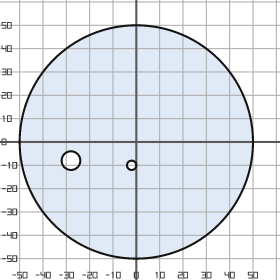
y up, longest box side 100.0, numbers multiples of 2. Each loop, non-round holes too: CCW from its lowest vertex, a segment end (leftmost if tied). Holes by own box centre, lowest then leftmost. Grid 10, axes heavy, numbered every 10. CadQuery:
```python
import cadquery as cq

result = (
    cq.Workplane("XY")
    .moveTo(0.0, 0.0)
    .circle(50.0)
    .moveTo(-2.0, -10.0)
    .circle(2.0)
    .moveTo(-28.0, -8.0)
    .circle(4.0)
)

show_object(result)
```